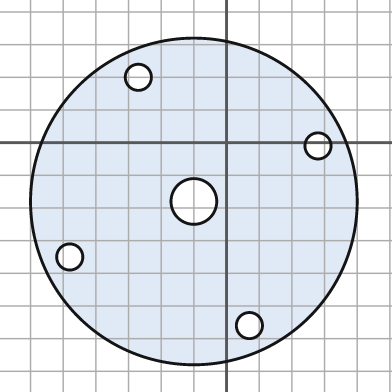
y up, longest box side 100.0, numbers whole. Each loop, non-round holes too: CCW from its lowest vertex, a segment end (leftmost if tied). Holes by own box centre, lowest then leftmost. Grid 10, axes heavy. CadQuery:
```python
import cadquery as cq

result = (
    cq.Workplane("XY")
    .moveTo(-10.0, -18.0)
    .circle(50.0)
    .moveTo(7.0, -56.0)
    .circle(4.0)
    .moveTo(-48.0, -35.0)
    .circle(4.0)
    .moveTo(-10.0, -18.0)
    .circle(7.0)
    .moveTo(28.0, -1.0)
    .circle(4.0)
    .moveTo(-27.0, 20.0)
    .circle(4.0)
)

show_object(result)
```